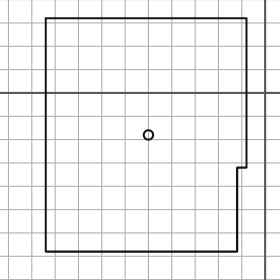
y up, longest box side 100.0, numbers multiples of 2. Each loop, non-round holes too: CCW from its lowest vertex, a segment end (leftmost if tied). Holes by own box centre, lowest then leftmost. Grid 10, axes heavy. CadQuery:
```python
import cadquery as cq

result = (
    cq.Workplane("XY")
    .moveTo(-94.0, -68.0)
    .lineTo(-12.0, -68.0)
    .lineTo(-12.0, -32.0)
    .lineTo(-8.0, -32.0)
    .lineTo(-8.0, 32.0)
    .lineTo(-94.0, 32.0)
    .close()
    .moveTo(-50.0, -18.0)
    .circle(2.0)
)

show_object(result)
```